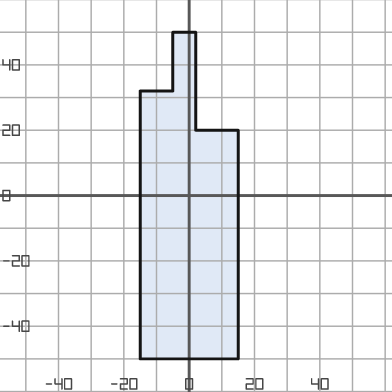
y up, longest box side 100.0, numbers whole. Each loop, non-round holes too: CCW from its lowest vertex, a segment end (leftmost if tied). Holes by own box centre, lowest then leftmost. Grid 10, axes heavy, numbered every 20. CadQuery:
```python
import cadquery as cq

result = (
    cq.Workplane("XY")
    .moveTo(-15.0, -50.0)
    .lineTo(15.0, -50.0)
    .lineTo(15.0, 20.0)
    .lineTo(2.0, 20.0)
    .lineTo(2.0, 50.0)
    .lineTo(-5.0, 50.0)
    .lineTo(-5.0, 32.0)
    .lineTo(-15.0, 32.0)
    .close()
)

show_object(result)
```